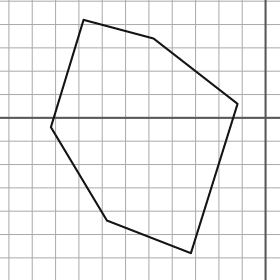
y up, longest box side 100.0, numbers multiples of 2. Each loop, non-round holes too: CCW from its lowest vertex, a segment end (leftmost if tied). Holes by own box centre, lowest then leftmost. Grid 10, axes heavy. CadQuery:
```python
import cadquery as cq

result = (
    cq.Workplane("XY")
    .moveTo(-32.0, -58.0)
    .lineTo(-12.0, 6.0)
    .lineTo(-48.0, 34.0)
    .lineTo(-78.0, 42.0)
    .lineTo(-92.0, -4.0)
    .lineTo(-68.0, -44.0)
    .close()
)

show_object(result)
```